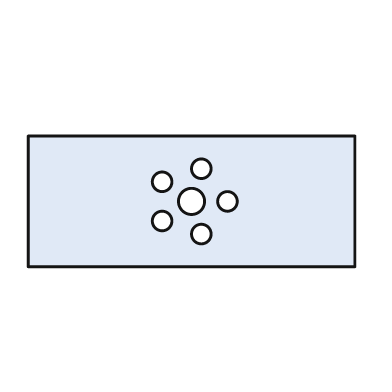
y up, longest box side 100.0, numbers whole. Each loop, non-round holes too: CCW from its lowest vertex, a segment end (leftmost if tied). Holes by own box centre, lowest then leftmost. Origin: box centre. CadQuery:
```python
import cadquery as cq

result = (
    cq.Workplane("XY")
    .moveTo(-50.0, -20.0)
    .lineTo(50.0, -20.0)
    .lineTo(50.0, 20.0)
    .lineTo(-50.0, 20.0)
    .close()
    .moveTo(3.0, -10.0)
    .circle(3.0)
    .moveTo(-9.0, -6.0)
    .circle(3.0)
    .moveTo(0.0, 0.0)
    .circle(4.0)
    .moveTo(11.0, 0.0)
    .circle(3.0)
    .moveTo(-9.0, 6.0)
    .circle(3.0)
    .moveTo(3.0, 10.0)
    .circle(3.0)
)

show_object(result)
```